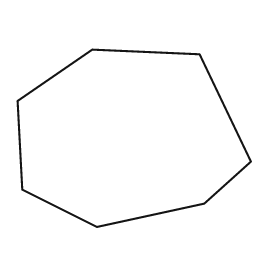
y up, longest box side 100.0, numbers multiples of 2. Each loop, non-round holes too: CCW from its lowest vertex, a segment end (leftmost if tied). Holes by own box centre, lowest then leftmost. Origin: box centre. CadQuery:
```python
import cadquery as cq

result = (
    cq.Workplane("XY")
    .moveTo(-16.0, -38.0)
    .lineTo(30.0, -28.0)
    .lineTo(50.0, -10.0)
    .lineTo(28.0, 36.0)
    .lineTo(-18.0, 38.0)
    .lineTo(-50.0, 16.0)
    .lineTo(-48.0, -22.0)
    .close()
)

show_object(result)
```